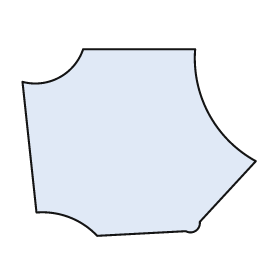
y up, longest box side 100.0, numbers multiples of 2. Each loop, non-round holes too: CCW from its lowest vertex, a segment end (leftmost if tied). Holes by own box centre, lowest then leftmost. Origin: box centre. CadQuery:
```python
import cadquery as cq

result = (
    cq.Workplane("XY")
    .moveTo(-18.0, -40.0)
    .lineTo(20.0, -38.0)
    .threePointArc((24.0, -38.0), (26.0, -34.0))
    .lineTo(50.0, -8.0)
    .threePointArc((30.0, 12.0), (24.0, 40.0))
    .lineTo(-24.0, 40.0)
    .threePointArc((-34.0, 28.0), (-50.0, 26.0))
    .lineTo(-44.0, -30.0)
    .threePointArc((-30.0, -32.0), (-18.0, -40.0))
    .close()
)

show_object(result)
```